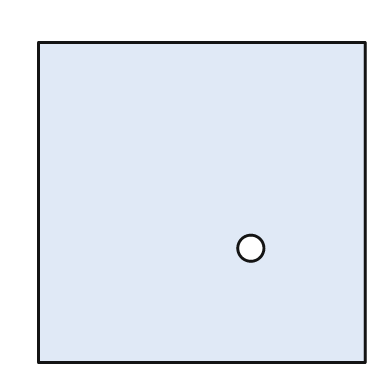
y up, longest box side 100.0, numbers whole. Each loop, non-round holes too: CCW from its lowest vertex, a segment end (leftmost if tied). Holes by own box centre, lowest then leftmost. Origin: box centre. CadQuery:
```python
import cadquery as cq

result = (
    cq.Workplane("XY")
    .moveTo(-50.0, -49.0)
    .lineTo(50.0, -49.0)
    .lineTo(50.0, 49.0)
    .lineTo(-50.0, 49.0)
    .close()
    .moveTo(15.0, -14.0)
    .circle(4.0)
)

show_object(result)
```